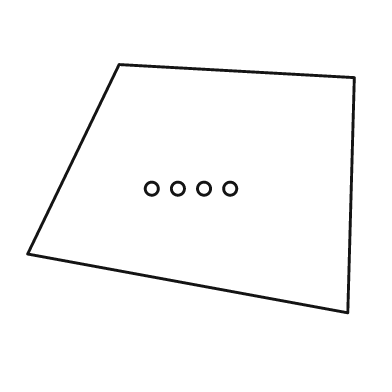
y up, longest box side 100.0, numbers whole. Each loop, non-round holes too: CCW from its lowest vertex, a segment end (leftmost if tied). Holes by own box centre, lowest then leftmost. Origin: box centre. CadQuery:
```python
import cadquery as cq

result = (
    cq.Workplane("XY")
    .moveTo(48.0, -38.0)
    .lineTo(50.0, 34.0)
    .lineTo(-22.0, 38.0)
    .lineTo(-50.0, -20.0)
    .close()
    .moveTo(-12.0, 0.0)
    .circle(2.0)
    .moveTo(-4.0, 0.0)
    .circle(2.0)
    .moveTo(4.0, 0.0)
    .circle(2.0)
    .moveTo(12.0, 0.0)
    .circle(2.0)
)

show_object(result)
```